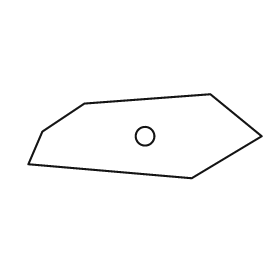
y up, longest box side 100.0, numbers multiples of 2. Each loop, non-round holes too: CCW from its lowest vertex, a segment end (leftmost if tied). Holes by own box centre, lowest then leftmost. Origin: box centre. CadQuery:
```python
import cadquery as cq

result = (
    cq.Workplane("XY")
    .moveTo(20.0, -18.0)
    .lineTo(50.0, 0.0)
    .lineTo(28.0, 18.0)
    .lineTo(-26.0, 14.0)
    .lineTo(-44.0, 2.0)
    .lineTo(-50.0, -12.0)
    .close()
    .moveTo(0.0, 0.0)
    .circle(4.0)
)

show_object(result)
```